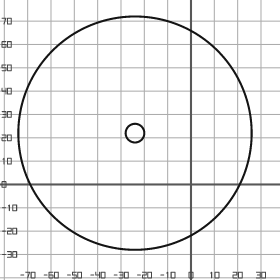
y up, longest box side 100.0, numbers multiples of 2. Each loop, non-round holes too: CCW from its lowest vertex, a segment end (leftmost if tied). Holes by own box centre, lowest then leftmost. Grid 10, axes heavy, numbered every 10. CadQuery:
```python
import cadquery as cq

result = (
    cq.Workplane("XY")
    .moveTo(-24.0, 22.0)
    .circle(50.0)
    .moveTo(-24.0, 22.0)
    .circle(4.0)
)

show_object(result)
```